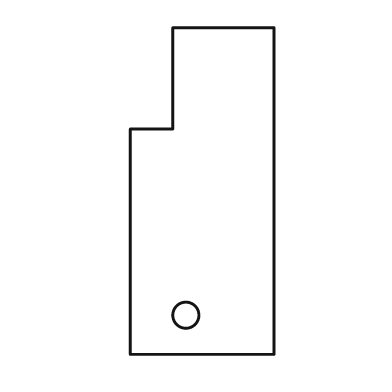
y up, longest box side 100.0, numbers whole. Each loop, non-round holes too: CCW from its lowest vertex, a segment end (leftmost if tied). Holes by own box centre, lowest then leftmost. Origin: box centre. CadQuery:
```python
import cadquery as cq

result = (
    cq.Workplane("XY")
    .moveTo(-22.0, -50.0)
    .lineTo(22.0, -50.0)
    .lineTo(22.0, 50.0)
    .lineTo(-9.0, 50.0)
    .lineTo(-9.0, 19.0)
    .lineTo(-22.0, 19.0)
    .close()
    .moveTo(-5.0, -38.0)
    .circle(4.0)
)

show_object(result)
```